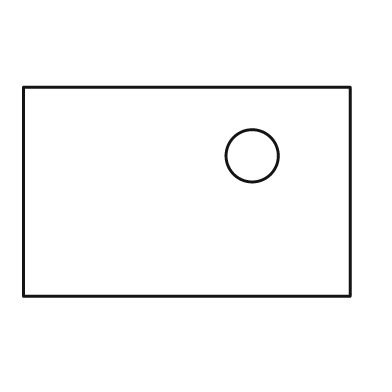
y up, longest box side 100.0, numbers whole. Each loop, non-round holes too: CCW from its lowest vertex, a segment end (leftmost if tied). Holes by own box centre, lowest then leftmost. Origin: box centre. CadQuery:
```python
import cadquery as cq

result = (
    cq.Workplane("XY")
    .moveTo(-50.0, -32.0)
    .lineTo(50.0, -32.0)
    .lineTo(50.0, 32.0)
    .lineTo(-50.0, 32.0)
    .close()
    .moveTo(20.0, 11.0)
    .circle(8.0)
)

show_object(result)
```